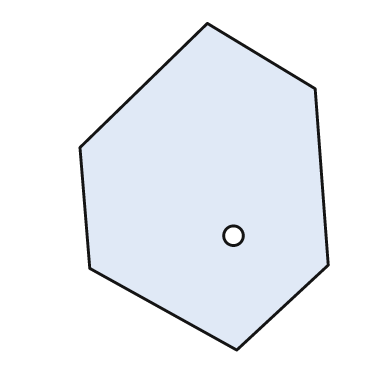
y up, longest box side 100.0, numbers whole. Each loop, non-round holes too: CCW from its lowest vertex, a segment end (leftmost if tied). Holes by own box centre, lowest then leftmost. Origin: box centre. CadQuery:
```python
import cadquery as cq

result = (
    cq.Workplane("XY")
    .moveTo(10.0, -50.0)
    .lineTo(38.0, -24.0)
    .lineTo(34.0, 30.0)
    .lineTo(1.0, 50.0)
    .lineTo(-38.0, 12.0)
    .lineTo(-35.0, -25.0)
    .close()
    .moveTo(9.0, -15.0)
    .circle(3.0)
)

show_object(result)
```